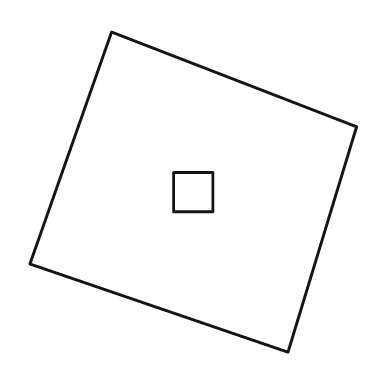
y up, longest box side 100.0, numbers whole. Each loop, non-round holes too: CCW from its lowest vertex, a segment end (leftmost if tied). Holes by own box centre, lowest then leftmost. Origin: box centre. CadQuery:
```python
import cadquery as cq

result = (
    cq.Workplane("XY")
    .moveTo(29.0, -49.0)
    .lineTo(50.0, 20.0)
    .lineTo(-25.0, 49.0)
    .lineTo(-50.0, -22.0)
    .close()
    .moveTo(-6.0, -6.0)
    .lineTo(6.0, -6.0)
    .lineTo(6.0, 6.0)
    .lineTo(-6.0, 6.0)
    .close()
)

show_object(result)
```